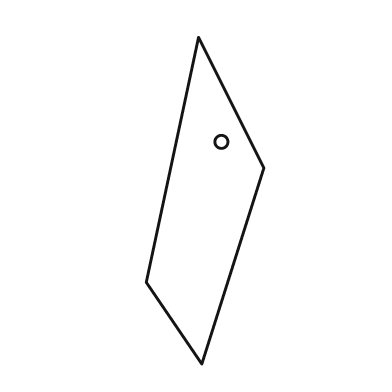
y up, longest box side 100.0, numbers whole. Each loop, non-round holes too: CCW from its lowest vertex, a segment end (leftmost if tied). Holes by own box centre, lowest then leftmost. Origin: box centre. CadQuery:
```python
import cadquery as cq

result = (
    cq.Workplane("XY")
    .moveTo(-1.0, -50.0)
    .lineTo(18.0, 10.0)
    .lineTo(-2.0, 50.0)
    .lineTo(-18.0, -25.0)
    .close()
    .moveTo(5.0, 18.0)
    .circle(2.0)
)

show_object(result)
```